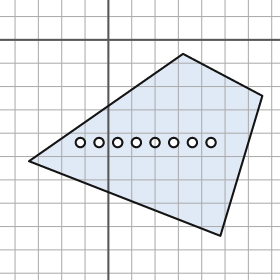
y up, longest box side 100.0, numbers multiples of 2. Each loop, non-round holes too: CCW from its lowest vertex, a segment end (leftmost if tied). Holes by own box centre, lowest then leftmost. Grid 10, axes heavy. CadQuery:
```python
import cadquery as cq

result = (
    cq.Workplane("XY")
    .moveTo(48.0, -84.0)
    .lineTo(66.0, -24.0)
    .lineTo(32.0, -6.0)
    .lineTo(-34.0, -52.0)
    .close()
    .moveTo(-12.0, -44.0)
    .circle(2.0)
    .moveTo(-4.0, -44.0)
    .circle(2.0)
    .moveTo(4.0, -44.0)
    .circle(2.0)
    .moveTo(12.0, -44.0)
    .circle(2.0)
    .moveTo(20.0, -44.0)
    .circle(2.0)
    .moveTo(28.0, -44.0)
    .circle(2.0)
    .moveTo(36.0, -44.0)
    .circle(2.0)
    .moveTo(44.0, -44.0)
    .circle(2.0)
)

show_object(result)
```